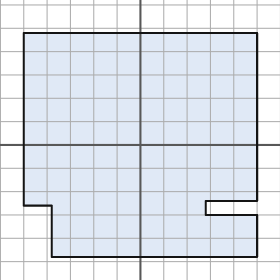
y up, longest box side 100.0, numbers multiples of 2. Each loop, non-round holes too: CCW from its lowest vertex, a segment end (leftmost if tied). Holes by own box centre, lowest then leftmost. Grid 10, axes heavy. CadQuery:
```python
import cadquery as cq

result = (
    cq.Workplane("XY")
    .moveTo(-38.0, -48.0)
    .lineTo(50.0, -48.0)
    .lineTo(50.0, -30.0)
    .lineTo(28.0, -30.0)
    .lineTo(28.0, -24.0)
    .lineTo(50.0, -24.0)
    .lineTo(50.0, 48.0)
    .lineTo(-50.0, 48.0)
    .lineTo(-50.0, -26.0)
    .lineTo(-38.0, -26.0)
    .close()
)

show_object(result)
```